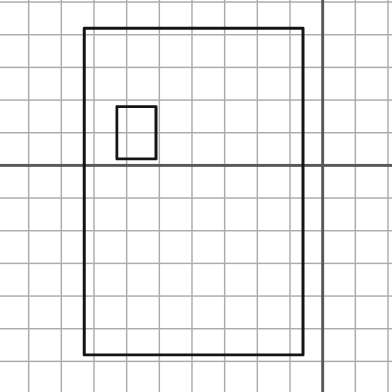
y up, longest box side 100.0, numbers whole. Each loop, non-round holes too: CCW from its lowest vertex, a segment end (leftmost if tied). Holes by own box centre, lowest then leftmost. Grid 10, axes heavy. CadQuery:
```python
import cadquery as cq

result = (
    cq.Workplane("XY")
    .moveTo(-73.0, -58.0)
    .lineTo(-6.0, -58.0)
    .lineTo(-6.0, 42.0)
    .lineTo(-73.0, 42.0)
    .close()
    .moveTo(-63.0, 2.0)
    .lineTo(-51.0, 2.0)
    .lineTo(-51.0, 18.0)
    .lineTo(-63.0, 18.0)
    .close()
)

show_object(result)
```